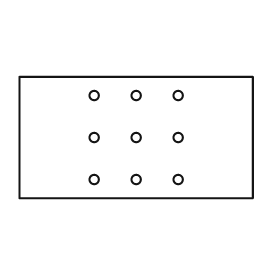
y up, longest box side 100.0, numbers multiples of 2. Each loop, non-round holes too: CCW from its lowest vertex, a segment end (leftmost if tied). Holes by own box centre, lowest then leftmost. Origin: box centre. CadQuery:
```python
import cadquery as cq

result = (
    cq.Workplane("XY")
    .moveTo(-50.0, -26.0)
    .lineTo(50.0, -26.0)
    .lineTo(50.0, 26.0)
    .lineTo(-50.0, 26.0)
    .close()
    .moveTo(-18.0, -18.0)
    .circle(2.0)
    .moveTo(0.0, -18.0)
    .circle(2.0)
    .moveTo(18.0, -18.0)
    .circle(2.0)
    .moveTo(-18.0, 0.0)
    .circle(2.0)
    .moveTo(0.0, 0.0)
    .circle(2.0)
    .moveTo(18.0, 0.0)
    .circle(2.0)
    .moveTo(-18.0, 18.0)
    .circle(2.0)
    .moveTo(0.0, 18.0)
    .circle(2.0)
    .moveTo(18.0, 18.0)
    .circle(2.0)
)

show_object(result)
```